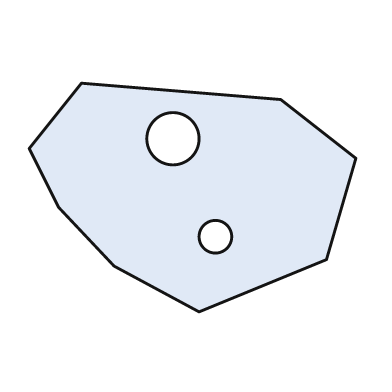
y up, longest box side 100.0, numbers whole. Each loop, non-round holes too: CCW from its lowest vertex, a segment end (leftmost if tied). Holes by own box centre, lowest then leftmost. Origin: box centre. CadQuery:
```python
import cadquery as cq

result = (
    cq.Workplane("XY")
    .moveTo(2.0, -35.0)
    .lineTo(41.0, -19.0)
    .lineTo(50.0, 12.0)
    .lineTo(27.0, 30.0)
    .lineTo(-34.0, 35.0)
    .lineTo(-50.0, 15.0)
    .lineTo(-41.0, -3.0)
    .lineTo(-24.0, -21.0)
    .close()
    .moveTo(7.0, -12.0)
    .circle(5.0)
    .moveTo(-6.0, 18.0)
    .circle(8.0)
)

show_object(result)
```